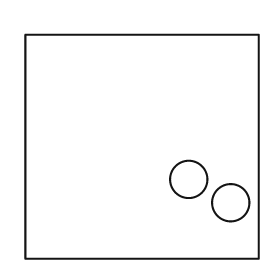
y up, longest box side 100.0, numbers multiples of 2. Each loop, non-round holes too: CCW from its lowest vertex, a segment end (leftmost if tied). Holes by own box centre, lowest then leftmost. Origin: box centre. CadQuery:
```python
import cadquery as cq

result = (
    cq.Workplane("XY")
    .moveTo(-50.0, -48.0)
    .lineTo(50.0, -48.0)
    .lineTo(50.0, 48.0)
    .lineTo(-50.0, 48.0)
    .close()
    .moveTo(38.0, -24.0)
    .circle(8.0)
    .moveTo(20.0, -14.0)
    .circle(8.0)
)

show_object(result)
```